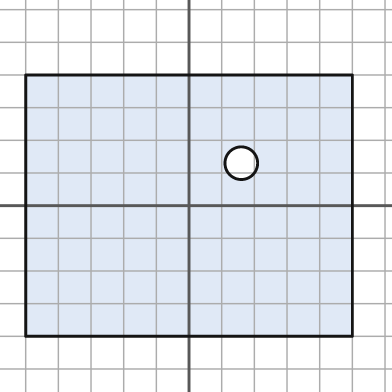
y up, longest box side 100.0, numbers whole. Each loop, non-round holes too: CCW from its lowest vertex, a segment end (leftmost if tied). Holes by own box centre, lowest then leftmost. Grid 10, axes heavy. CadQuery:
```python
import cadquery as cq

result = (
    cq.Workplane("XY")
    .moveTo(-50.0, -40.0)
    .lineTo(50.0, -40.0)
    .lineTo(50.0, 40.0)
    .lineTo(-50.0, 40.0)
    .close()
    .moveTo(16.0, 13.0)
    .circle(5.0)
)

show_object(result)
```